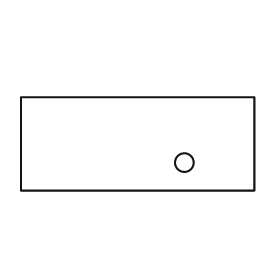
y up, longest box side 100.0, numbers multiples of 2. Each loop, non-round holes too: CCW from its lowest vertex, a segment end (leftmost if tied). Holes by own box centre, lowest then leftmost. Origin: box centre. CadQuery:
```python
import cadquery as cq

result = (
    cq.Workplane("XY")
    .moveTo(-50.0, -20.0)
    .lineTo(50.0, -20.0)
    .lineTo(50.0, 20.0)
    .lineTo(-50.0, 20.0)
    .close()
    .moveTo(20.0, -8.0)
    .circle(4.0)
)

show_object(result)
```